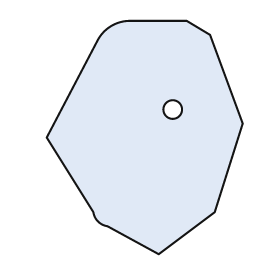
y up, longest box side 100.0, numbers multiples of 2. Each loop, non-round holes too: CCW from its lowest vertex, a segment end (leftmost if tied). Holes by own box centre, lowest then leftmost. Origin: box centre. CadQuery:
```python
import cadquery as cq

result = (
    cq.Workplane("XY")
    .moveTo(6.0, -50.0)
    .lineTo(30.0, -32.0)
    .lineTo(42.0, 6.0)
    .lineTo(28.0, 44.0)
    .lineTo(18.0, 50.0)
    .lineTo(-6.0, 50.0)
    .threePointArc((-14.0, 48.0), (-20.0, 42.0))
    .lineTo(-42.0, 0.0)
    .lineTo(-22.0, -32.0)
    .threePointArc((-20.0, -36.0), (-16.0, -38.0))
    .close()
    .moveTo(12.0, 12.0)
    .circle(4.0)
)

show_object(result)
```